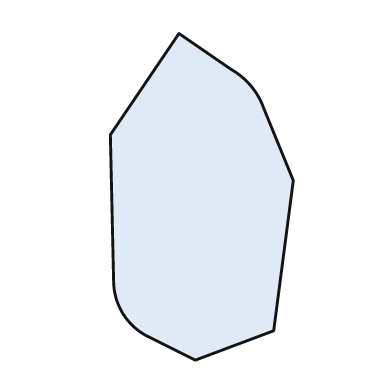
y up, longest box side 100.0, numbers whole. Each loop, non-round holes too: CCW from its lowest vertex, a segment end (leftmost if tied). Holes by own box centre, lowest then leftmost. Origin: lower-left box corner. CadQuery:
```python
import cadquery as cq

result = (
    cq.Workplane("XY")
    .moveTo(26.0, 0.0)
    .lineTo(50.0, 9.0)
    .lineTo(56.0, 55.0)
    .lineTo(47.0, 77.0)
    .threePointArc((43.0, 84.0), (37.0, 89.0))
    .lineTo(21.0, 100.0)
    .lineTo(0.0, 69.0)
    .lineTo(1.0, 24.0)
    .threePointArc((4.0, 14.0), (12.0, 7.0))
    .close()
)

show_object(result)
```